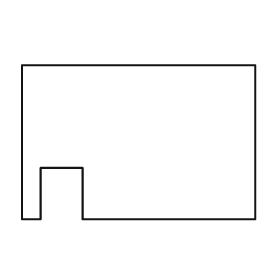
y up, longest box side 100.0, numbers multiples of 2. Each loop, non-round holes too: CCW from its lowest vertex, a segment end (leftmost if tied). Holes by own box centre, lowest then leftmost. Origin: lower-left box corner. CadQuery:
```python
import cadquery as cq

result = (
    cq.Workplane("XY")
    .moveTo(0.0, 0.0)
    .lineTo(8.0, 0.0)
    .lineTo(8.0, 22.0)
    .lineTo(26.0, 22.0)
    .lineTo(26.0, 0.0)
    .lineTo(100.0, 0.0)
    .lineTo(100.0, 66.0)
    .lineTo(0.0, 66.0)
    .close()
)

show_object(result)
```